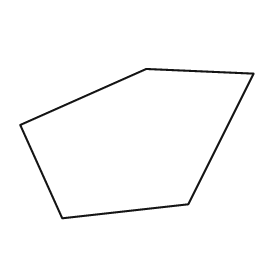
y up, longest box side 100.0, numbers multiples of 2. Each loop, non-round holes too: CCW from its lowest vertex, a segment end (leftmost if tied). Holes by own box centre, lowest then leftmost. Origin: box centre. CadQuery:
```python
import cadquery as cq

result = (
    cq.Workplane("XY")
    .moveTo(-32.0, -32.0)
    .lineTo(22.0, -26.0)
    .lineTo(50.0, 30.0)
    .lineTo(4.0, 32.0)
    .lineTo(-50.0, 8.0)
    .close()
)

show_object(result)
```